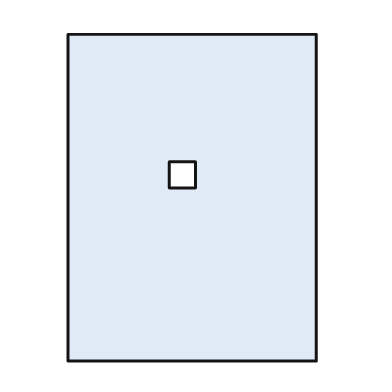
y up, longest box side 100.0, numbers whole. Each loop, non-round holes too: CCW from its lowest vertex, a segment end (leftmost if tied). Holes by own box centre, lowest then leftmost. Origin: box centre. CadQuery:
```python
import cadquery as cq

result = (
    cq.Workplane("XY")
    .moveTo(-38.0, -50.0)
    .lineTo(38.0, -50.0)
    .lineTo(38.0, 50.0)
    .lineTo(-38.0, 50.0)
    .close()
    .moveTo(-7.0, 3.0)
    .lineTo(1.0, 3.0)
    .lineTo(1.0, 11.0)
    .lineTo(-7.0, 11.0)
    .close()
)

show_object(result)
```